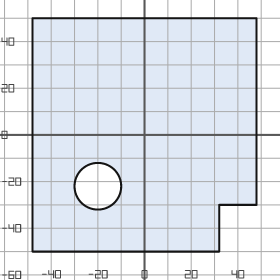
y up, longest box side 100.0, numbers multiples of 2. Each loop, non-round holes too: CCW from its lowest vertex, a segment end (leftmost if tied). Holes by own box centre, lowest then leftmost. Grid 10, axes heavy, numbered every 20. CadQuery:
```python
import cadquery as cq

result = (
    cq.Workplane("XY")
    .moveTo(-48.0, -50.0)
    .lineTo(32.0, -50.0)
    .lineTo(32.0, -30.0)
    .lineTo(48.0, -30.0)
    .lineTo(48.0, 50.0)
    .lineTo(-48.0, 50.0)
    .close()
    .moveTo(-20.0, -22.0)
    .circle(10.0)
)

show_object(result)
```